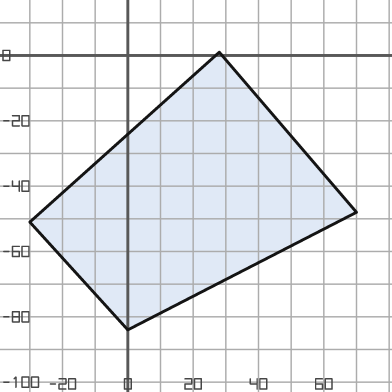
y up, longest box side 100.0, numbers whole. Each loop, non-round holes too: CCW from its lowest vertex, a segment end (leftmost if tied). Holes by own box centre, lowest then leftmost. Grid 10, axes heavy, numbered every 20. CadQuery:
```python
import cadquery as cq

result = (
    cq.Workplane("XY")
    .moveTo(0.0, -84.0)
    .lineTo(70.0, -48.0)
    .lineTo(28.0, 1.0)
    .lineTo(-30.0, -51.0)
    .close()
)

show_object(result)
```